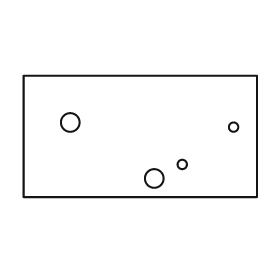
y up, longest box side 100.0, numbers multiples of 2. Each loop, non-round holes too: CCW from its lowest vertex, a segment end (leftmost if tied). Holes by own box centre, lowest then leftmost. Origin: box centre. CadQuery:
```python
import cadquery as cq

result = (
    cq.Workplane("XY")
    .moveTo(-50.0, -26.0)
    .lineTo(50.0, -26.0)
    .lineTo(50.0, 26.0)
    .lineTo(-50.0, 26.0)
    .close()
    .moveTo(6.0, -18.0)
    .circle(4.0)
    .moveTo(18.0, -12.0)
    .circle(2.0)
    .moveTo(40.0, 4.0)
    .circle(2.0)
    .moveTo(-30.0, 6.0)
    .circle(4.0)
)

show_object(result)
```